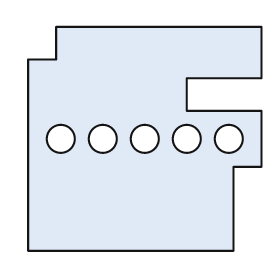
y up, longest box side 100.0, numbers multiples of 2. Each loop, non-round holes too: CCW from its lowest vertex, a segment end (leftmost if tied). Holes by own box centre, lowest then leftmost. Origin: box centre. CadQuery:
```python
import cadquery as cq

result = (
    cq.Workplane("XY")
    .moveTo(-50.0, -48.0)
    .lineTo(38.0, -48.0)
    .lineTo(38.0, -12.0)
    .lineTo(50.0, -12.0)
    .lineTo(50.0, 12.0)
    .lineTo(18.0, 12.0)
    .lineTo(18.0, 26.0)
    .lineTo(50.0, 26.0)
    .lineTo(50.0, 48.0)
    .lineTo(-38.0, 48.0)
    .lineTo(-38.0, 34.0)
    .lineTo(-50.0, 34.0)
    .close()
    .moveTo(-36.0, 0.0)
    .circle(6.0)
    .moveTo(-18.0, 0.0)
    .circle(6.0)
    .moveTo(0.0, 0.0)
    .circle(6.0)
    .moveTo(18.0, 0.0)
    .circle(6.0)
    .moveTo(36.0, 0.0)
    .circle(6.0)
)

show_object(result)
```